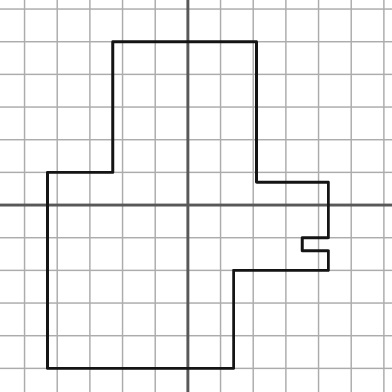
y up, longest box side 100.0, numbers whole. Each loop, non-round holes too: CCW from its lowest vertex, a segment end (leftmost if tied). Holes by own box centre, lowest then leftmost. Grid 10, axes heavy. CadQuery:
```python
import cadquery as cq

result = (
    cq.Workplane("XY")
    .moveTo(-43.0, -50.0)
    .lineTo(14.0, -50.0)
    .lineTo(14.0, -20.0)
    .lineTo(43.0, -20.0)
    .lineTo(43.0, -14.0)
    .lineTo(35.0, -14.0)
    .lineTo(35.0, -10.0)
    .lineTo(43.0, -10.0)
    .lineTo(43.0, 7.0)
    .lineTo(21.0, 7.0)
    .lineTo(21.0, 50.0)
    .lineTo(-23.0, 50.0)
    .lineTo(-23.0, 10.0)
    .lineTo(-43.0, 10.0)
    .close()
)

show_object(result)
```